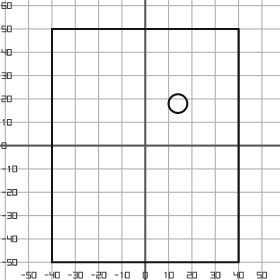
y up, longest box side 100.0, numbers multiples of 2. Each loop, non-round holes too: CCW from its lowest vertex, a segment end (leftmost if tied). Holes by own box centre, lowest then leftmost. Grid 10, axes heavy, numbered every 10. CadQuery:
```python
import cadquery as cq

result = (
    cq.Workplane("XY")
    .moveTo(-40.0, -50.0)
    .lineTo(40.0, -50.0)
    .lineTo(40.0, 50.0)
    .lineTo(-40.0, 50.0)
    .close()
    .moveTo(14.0, 18.0)
    .circle(4.0)
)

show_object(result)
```